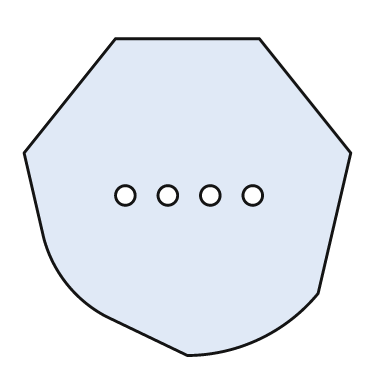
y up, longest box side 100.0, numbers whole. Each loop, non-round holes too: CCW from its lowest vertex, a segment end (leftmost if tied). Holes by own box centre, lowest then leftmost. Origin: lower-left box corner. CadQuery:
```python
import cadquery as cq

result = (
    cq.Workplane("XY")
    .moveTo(50.0, 0.0)
    .threePointArc((72.0, 5.0), (90.0, 19.0))
    .lineTo(100.0, 62.0)
    .lineTo(72.0, 97.0)
    .lineTo(28.0, 97.0)
    .lineTo(0.0, 62.0)
    .lineTo(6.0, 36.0)
    .threePointArc((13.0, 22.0), (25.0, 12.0))
    .close()
    .moveTo(31.0, 49.0)
    .circle(3.0)
    .moveTo(44.0, 49.0)
    .circle(3.0)
    .moveTo(57.0, 49.0)
    .circle(3.0)
    .moveTo(70.0, 49.0)
    .circle(3.0)
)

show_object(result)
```